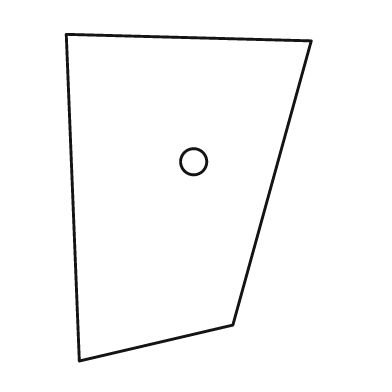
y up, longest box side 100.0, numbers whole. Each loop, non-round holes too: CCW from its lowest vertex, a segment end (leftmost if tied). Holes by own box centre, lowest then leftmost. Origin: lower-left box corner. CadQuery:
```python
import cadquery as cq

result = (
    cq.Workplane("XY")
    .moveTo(4.0, 0.0)
    .lineTo(51.0, 11.0)
    .lineTo(75.0, 98.0)
    .lineTo(0.0, 100.0)
    .close()
    .moveTo(39.0, 61.0)
    .circle(4.0)
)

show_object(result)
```